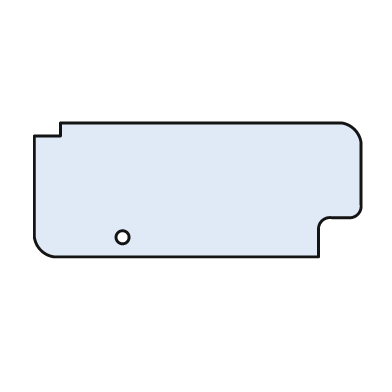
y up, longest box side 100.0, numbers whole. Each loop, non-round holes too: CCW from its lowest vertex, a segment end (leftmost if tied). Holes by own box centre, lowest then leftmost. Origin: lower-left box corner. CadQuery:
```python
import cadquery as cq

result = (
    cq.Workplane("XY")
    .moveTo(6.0, 0.0)
    .lineTo(87.0, 0.0)
    .lineTo(87.0, 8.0)
    .threePointArc((88.0, 11.0), (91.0, 12.0))
    .lineTo(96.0, 12.0)
    .threePointArc((99.0, 13.0), (100.0, 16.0))
    .lineTo(100.0, 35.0)
    .threePointArc((98.0, 39.0), (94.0, 41.0))
    .lineTo(8.0, 41.0)
    .lineTo(8.0, 37.0)
    .lineTo(0.0, 37.0)
    .lineTo(0.0, 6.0)
    .threePointArc((2.0, 2.0), (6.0, 0.0))
    .close()
    .moveTo(27.0, 6.0)
    .circle(2.0)
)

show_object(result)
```